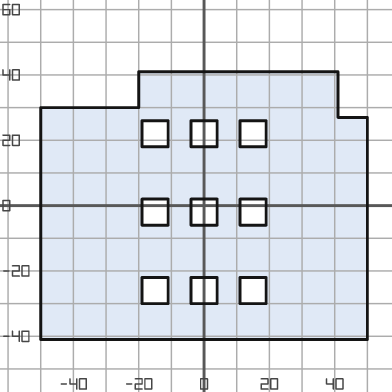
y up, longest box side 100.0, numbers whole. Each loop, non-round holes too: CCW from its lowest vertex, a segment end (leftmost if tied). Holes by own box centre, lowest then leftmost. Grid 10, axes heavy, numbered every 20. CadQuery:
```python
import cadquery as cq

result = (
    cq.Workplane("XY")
    .moveTo(-50.0, -41.0)
    .lineTo(50.0, -41.0)
    .lineTo(50.0, 27.0)
    .lineTo(41.0, 27.0)
    .lineTo(41.0, 41.0)
    .lineTo(-20.0, 41.0)
    .lineTo(-20.0, 30.0)
    .lineTo(-50.0, 30.0)
    .close()
    .moveTo(-19.0, -30.0)
    .lineTo(-11.0, -30.0)
    .lineTo(-11.0, -22.0)
    .lineTo(-19.0, -22.0)
    .close()
    .moveTo(-4.0, -30.0)
    .lineTo(4.0, -30.0)
    .lineTo(4.0, -22.0)
    .lineTo(-4.0, -22.0)
    .close()
    .moveTo(11.0, -30.0)
    .lineTo(19.0, -30.0)
    .lineTo(19.0, -22.0)
    .lineTo(11.0, -22.0)
    .close()
    .moveTo(-19.0, -6.0)
    .lineTo(-11.0, -6.0)
    .lineTo(-11.0, 2.0)
    .lineTo(-19.0, 2.0)
    .close()
    .moveTo(-4.0, -6.0)
    .lineTo(4.0, -6.0)
    .lineTo(4.0, 2.0)
    .lineTo(-4.0, 2.0)
    .close()
    .moveTo(11.0, -6.0)
    .lineTo(19.0, -6.0)
    .lineTo(19.0, 2.0)
    .lineTo(11.0, 2.0)
    .close()
    .moveTo(-19.0, 18.0)
    .lineTo(-11.0, 18.0)
    .lineTo(-11.0, 26.0)
    .lineTo(-19.0, 26.0)
    .close()
    .moveTo(-4.0, 18.0)
    .lineTo(4.0, 18.0)
    .lineTo(4.0, 26.0)
    .lineTo(-4.0, 26.0)
    .close()
    .moveTo(11.0, 18.0)
    .lineTo(19.0, 18.0)
    .lineTo(19.0, 26.0)
    .lineTo(11.0, 26.0)
    .close()
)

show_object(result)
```